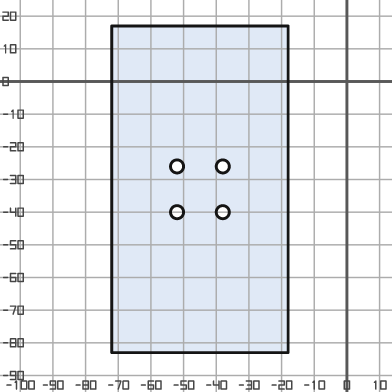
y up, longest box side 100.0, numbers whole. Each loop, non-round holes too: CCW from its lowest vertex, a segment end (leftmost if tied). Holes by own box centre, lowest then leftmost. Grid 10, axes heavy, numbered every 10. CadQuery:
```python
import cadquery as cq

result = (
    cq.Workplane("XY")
    .moveTo(-72.0, -83.0)
    .lineTo(-18.0, -83.0)
    .lineTo(-18.0, 17.0)
    .lineTo(-72.0, 17.0)
    .close()
    .moveTo(-52.0, -40.0)
    .circle(2.0)
    .moveTo(-38.0, -40.0)
    .circle(2.0)
    .moveTo(-52.0, -26.0)
    .circle(2.0)
    .moveTo(-38.0, -26.0)
    .circle(2.0)
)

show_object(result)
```